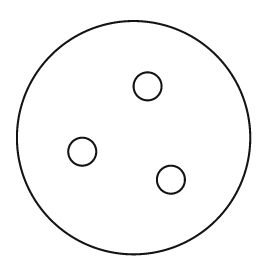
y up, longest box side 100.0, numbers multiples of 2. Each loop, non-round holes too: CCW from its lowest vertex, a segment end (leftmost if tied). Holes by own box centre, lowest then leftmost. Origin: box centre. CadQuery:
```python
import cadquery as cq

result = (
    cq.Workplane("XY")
    .moveTo(0.0, 0.0)
    .circle(50.0)
    .moveTo(16.0, -18.0)
    .circle(6.0)
    .moveTo(-22.0, -6.0)
    .circle(6.0)
    .moveTo(6.0, 22.0)
    .circle(6.0)
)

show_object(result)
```